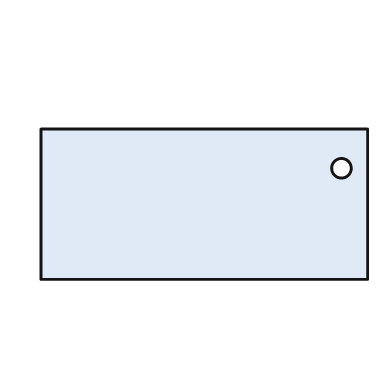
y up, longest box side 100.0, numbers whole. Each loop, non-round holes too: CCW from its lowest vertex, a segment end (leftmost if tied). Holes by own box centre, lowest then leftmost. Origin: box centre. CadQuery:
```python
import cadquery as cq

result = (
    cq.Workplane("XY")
    .moveTo(-50.0, -23.0)
    .lineTo(50.0, -23.0)
    .lineTo(50.0, 23.0)
    .lineTo(-50.0, 23.0)
    .close()
    .moveTo(42.0, 11.0)
    .circle(3.0)
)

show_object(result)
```